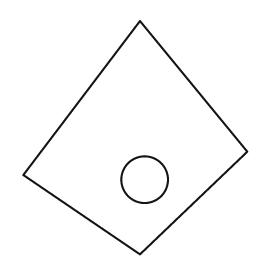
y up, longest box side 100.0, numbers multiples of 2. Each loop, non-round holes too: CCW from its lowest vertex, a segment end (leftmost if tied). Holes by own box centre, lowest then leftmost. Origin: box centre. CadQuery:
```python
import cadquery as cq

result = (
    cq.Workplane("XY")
    .moveTo(2.0, -50.0)
    .lineTo(48.0, -6.0)
    .lineTo(2.0, 50.0)
    .lineTo(-48.0, -16.0)
    .close()
    .moveTo(4.0, -18.0)
    .circle(10.0)
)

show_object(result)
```